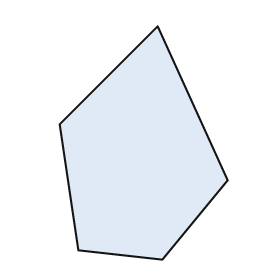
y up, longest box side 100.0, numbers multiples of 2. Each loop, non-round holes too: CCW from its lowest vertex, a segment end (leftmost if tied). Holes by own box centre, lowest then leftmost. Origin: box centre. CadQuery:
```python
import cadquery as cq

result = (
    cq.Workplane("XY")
    .moveTo(8.0, -50.0)
    .lineTo(36.0, -16.0)
    .lineTo(6.0, 50.0)
    .lineTo(-36.0, 8.0)
    .lineTo(-28.0, -46.0)
    .close()
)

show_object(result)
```